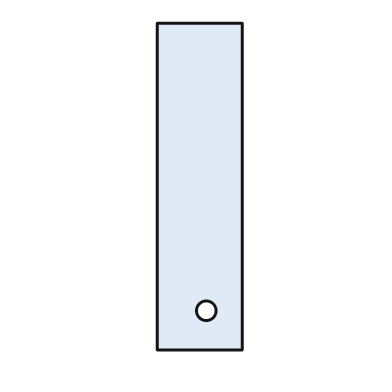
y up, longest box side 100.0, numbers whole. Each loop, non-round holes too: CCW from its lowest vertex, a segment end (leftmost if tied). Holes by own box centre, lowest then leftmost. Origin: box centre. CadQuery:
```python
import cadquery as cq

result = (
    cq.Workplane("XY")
    .moveTo(-13.0, -50.0)
    .lineTo(13.0, -50.0)
    .lineTo(13.0, 50.0)
    .lineTo(-13.0, 50.0)
    .close()
    .moveTo(2.0, -38.0)
    .circle(3.0)
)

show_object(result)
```